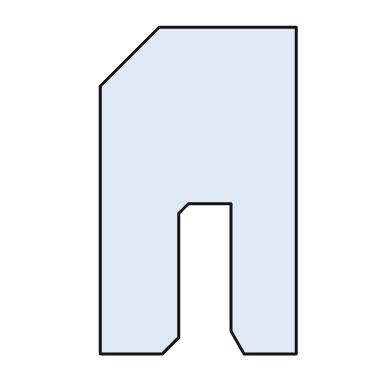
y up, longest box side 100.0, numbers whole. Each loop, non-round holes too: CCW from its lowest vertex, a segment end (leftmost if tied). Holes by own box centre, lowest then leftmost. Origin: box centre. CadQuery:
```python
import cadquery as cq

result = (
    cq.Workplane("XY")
    .moveTo(-30.0, -50.0)
    .lineTo(-11.0, -50.0)
    .lineTo(-6.0, -45.0)
    .lineTo(-6.0, -7.0)
    .lineTo(-3.0, -4.0)
    .lineTo(10.0, -4.0)
    .lineTo(10.0, -43.0)
    .lineTo(14.0, -50.0)
    .lineTo(30.0, -50.0)
    .lineTo(30.0, 50.0)
    .lineTo(-12.0, 50.0)
    .lineTo(-30.0, 32.0)
    .close()
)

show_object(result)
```